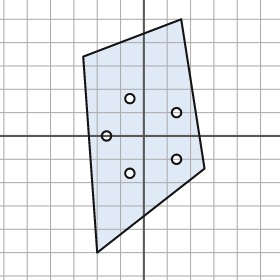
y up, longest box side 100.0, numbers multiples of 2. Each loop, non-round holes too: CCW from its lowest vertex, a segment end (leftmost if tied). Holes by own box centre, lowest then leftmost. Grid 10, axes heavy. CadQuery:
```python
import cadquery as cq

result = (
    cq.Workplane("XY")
    .moveTo(-20.0, -50.0)
    .lineTo(26.0, -14.0)
    .lineTo(16.0, 50.0)
    .lineTo(-26.0, 34.0)
    .close()
    .moveTo(-6.0, -16.0)
    .circle(2.0)
    .moveTo(14.0, -10.0)
    .circle(2.0)
    .moveTo(-16.0, 0.0)
    .circle(2.0)
    .moveTo(14.0, 10.0)
    .circle(2.0)
    .moveTo(-6.0, 16.0)
    .circle(2.0)
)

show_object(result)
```